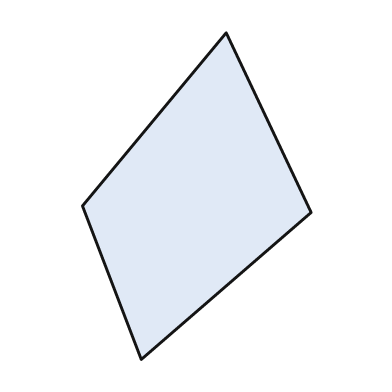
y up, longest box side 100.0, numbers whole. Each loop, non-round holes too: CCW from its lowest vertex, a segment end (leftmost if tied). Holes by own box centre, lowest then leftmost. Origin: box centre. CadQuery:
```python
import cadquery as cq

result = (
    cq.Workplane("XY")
    .moveTo(-17.0, -50.0)
    .lineTo(35.0, -5.0)
    .lineTo(9.0, 50.0)
    .lineTo(-35.0, -3.0)
    .close()
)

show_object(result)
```